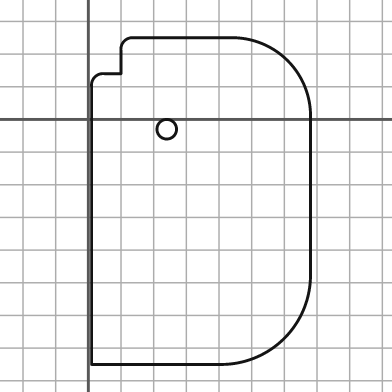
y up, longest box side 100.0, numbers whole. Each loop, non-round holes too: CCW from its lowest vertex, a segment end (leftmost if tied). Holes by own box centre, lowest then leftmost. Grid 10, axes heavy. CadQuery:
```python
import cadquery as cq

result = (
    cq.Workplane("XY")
    .moveTo(1.0, -75.0)
    .lineTo(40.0, -75.0)
    .threePointArc((60.0, -67.0), (68.0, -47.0))
    .lineTo(68.0, 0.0)
    .threePointArc((61.0, 18.0), (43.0, 25.0))
    .lineTo(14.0, 25.0)
    .threePointArc((11.0, 24.0), (10.0, 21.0))
    .lineTo(10.0, 14.0)
    .lineTo(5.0, 14.0)
    .threePointArc((2.0, 13.0), (1.0, 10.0))
    .close()
    .moveTo(24.0, -3.0)
    .circle(3.0)
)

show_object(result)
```